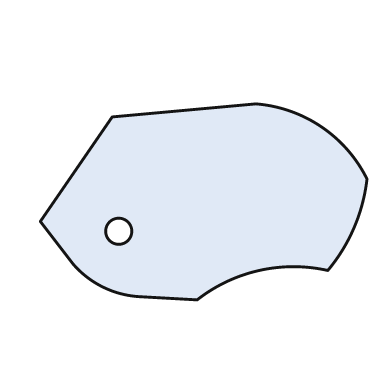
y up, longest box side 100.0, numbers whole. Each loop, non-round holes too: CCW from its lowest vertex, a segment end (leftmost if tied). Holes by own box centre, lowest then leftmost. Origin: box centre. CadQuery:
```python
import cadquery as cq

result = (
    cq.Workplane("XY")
    .moveTo(-2.0, -30.0)
    .threePointArc((17.0, -21.0), (38.0, -21.0))
    .threePointArc((46.0, -8.0), (50.0, 7.0))
    .threePointArc((36.0, 23.0), (16.0, 30.0))
    .lineTo(-28.0, 26.0)
    .lineTo(-50.0, -6.0)
    .lineTo(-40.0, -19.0)
    .threePointArc((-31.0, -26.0), (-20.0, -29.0))
    .close()
    .moveTo(-26.0, -9.0)
    .circle(4.0)
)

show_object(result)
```